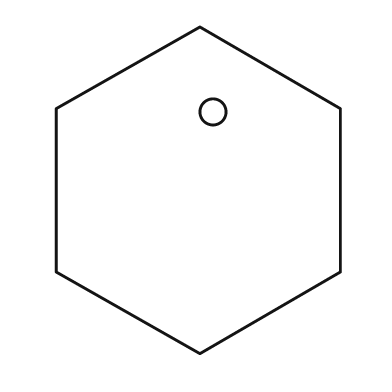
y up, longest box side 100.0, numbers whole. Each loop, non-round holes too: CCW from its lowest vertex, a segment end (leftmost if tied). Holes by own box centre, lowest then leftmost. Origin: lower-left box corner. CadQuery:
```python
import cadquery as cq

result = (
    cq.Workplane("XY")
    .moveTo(44.0, 0.0)
    .lineTo(87.0, 25.0)
    .lineTo(87.0, 75.0)
    .lineTo(44.0, 100.0)
    .lineTo(0.0, 75.0)
    .lineTo(0.0, 25.0)
    .close()
    .moveTo(48.0, 74.0)
    .circle(4.0)
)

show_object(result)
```